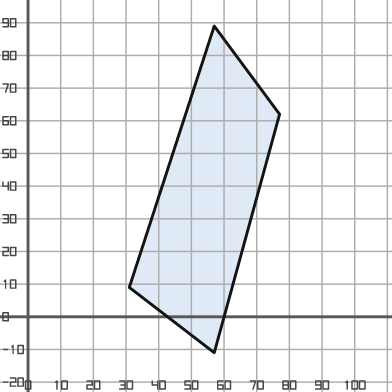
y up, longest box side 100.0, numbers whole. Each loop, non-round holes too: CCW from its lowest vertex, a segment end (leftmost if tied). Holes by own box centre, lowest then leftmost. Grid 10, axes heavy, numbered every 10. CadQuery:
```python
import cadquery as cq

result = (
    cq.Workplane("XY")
    .moveTo(57.0, -11.0)
    .lineTo(77.0, 62.0)
    .lineTo(57.0, 89.0)
    .lineTo(31.0, 9.0)
    .close()
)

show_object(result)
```